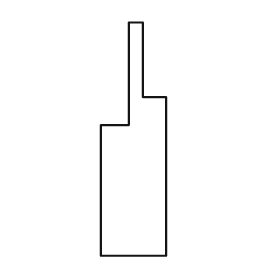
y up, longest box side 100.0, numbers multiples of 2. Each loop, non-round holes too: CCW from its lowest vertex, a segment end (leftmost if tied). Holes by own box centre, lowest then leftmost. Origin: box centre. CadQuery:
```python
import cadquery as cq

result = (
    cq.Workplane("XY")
    .moveTo(-14.0, -50.0)
    .lineTo(14.0, -50.0)
    .lineTo(14.0, 18.0)
    .lineTo(4.0, 18.0)
    .lineTo(4.0, 50.0)
    .lineTo(-2.0, 50.0)
    .lineTo(-2.0, 6.0)
    .lineTo(-14.0, 6.0)
    .close()
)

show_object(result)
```